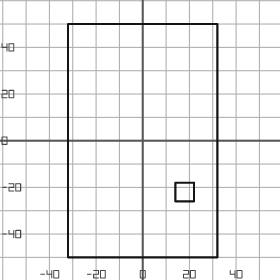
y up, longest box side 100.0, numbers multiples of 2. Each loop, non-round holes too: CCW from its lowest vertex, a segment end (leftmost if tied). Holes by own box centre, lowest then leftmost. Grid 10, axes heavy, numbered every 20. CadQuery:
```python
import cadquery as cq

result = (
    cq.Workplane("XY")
    .moveTo(-32.0, -50.0)
    .lineTo(32.0, -50.0)
    .lineTo(32.0, 50.0)
    .lineTo(-32.0, 50.0)
    .close()
    .moveTo(14.0, -26.0)
    .lineTo(22.0, -26.0)
    .lineTo(22.0, -18.0)
    .lineTo(14.0, -18.0)
    .close()
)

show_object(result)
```